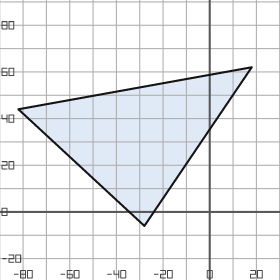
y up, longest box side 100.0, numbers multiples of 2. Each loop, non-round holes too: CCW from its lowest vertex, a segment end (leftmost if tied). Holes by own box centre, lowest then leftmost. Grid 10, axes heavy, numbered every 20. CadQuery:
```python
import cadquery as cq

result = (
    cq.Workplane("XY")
    .moveTo(-28.0, -6.0)
    .lineTo(18.0, 62.0)
    .lineTo(-82.0, 44.0)
    .close()
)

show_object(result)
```